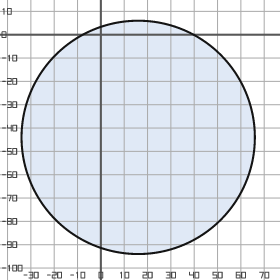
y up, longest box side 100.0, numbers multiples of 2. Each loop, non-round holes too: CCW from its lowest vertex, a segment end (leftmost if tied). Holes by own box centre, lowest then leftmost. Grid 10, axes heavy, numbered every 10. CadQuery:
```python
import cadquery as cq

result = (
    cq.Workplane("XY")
    .moveTo(16.0, -44.0)
    .circle(50.0)
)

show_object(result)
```